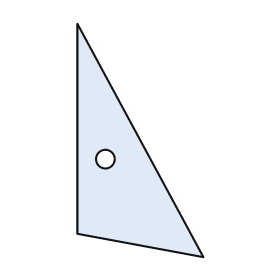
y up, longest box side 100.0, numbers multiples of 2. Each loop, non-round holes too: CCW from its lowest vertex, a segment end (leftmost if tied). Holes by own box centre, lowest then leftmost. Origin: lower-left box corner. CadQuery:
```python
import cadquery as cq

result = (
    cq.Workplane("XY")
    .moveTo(54.0, 0.0)
    .lineTo(0.0, 100.0)
    .lineTo(0.0, 10.0)
    .close()
    .moveTo(12.0, 42.0)
    .circle(4.0)
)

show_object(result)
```